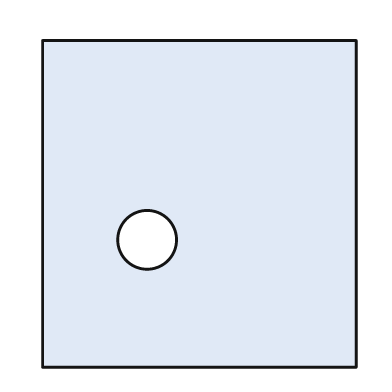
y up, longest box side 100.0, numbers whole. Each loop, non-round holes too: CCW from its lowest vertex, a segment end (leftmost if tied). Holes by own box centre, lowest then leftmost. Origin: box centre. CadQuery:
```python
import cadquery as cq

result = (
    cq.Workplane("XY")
    .moveTo(-48.0, -50.0)
    .lineTo(48.0, -50.0)
    .lineTo(48.0, 50.0)
    .lineTo(-48.0, 50.0)
    .close()
    .moveTo(-16.0, -11.0)
    .circle(9.0)
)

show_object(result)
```